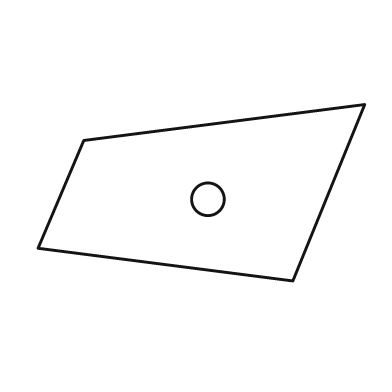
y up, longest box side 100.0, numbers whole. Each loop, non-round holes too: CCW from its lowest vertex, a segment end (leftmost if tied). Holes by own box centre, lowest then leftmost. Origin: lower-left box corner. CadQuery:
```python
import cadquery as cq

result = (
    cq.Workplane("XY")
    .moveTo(78.0, 0.0)
    .lineTo(100.0, 54.0)
    .lineTo(14.0, 43.0)
    .lineTo(0.0, 10.0)
    .close()
    .moveTo(52.0, 25.0)
    .circle(5.0)
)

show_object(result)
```